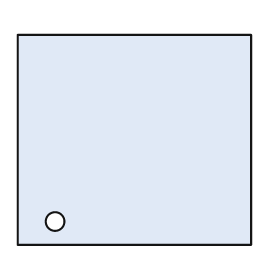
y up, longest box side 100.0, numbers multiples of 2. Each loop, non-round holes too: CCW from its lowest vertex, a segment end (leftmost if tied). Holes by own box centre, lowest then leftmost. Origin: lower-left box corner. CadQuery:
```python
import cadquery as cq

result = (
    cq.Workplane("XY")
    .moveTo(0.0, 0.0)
    .lineTo(100.0, 0.0)
    .lineTo(100.0, 90.0)
    .lineTo(0.0, 90.0)
    .close()
    .moveTo(16.0, 10.0)
    .circle(4.0)
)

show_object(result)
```